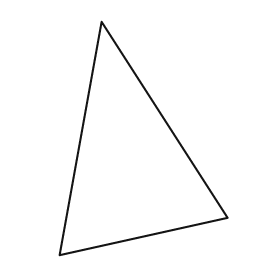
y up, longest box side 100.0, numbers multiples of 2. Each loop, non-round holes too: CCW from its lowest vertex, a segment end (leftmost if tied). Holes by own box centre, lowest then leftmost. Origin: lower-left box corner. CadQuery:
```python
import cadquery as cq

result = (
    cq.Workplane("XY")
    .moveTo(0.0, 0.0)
    .lineTo(72.0, 16.0)
    .lineTo(18.0, 100.0)
    .close()
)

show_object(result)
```